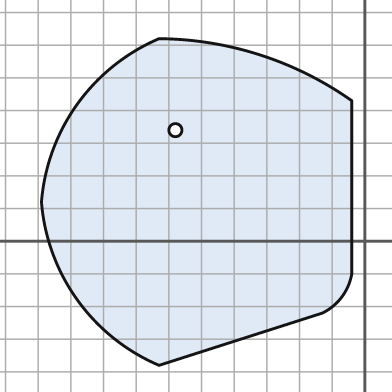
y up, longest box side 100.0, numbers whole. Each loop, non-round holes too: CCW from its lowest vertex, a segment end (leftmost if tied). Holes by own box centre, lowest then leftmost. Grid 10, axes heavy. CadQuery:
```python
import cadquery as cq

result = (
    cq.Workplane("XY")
    .moveTo(-63.0, -38.0)
    .lineTo(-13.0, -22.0)
    .threePointArc((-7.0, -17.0), (-4.0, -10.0))
    .lineTo(-4.0, 43.0)
    .threePointArc((-32.0, 57.0), (-63.0, 62.0))
    .threePointArc((-88.0, 42.0), (-99.0, 12.0))
    .threePointArc((-88.0, -18.0), (-63.0, -38.0))
    .close()
    .moveTo(-58.0, 34.0)
    .circle(2.0)
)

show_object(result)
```